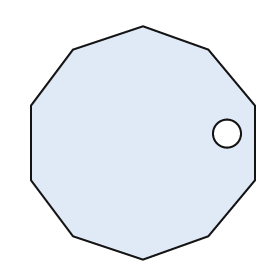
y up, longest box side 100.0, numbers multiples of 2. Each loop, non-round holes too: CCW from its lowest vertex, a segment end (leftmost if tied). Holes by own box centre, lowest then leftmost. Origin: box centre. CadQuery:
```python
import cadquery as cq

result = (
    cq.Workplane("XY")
    .moveTo(0.0, -50.0)
    .lineTo(28.0, -40.0)
    .lineTo(48.0, -16.0)
    .lineTo(48.0, 16.0)
    .lineTo(28.0, 40.0)
    .lineTo(0.0, 50.0)
    .lineTo(-30.0, 40.0)
    .lineTo(-48.0, 16.0)
    .lineTo(-48.0, -16.0)
    .lineTo(-30.0, -40.0)
    .close()
    .moveTo(36.0, 4.0)
    .circle(6.0)
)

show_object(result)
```